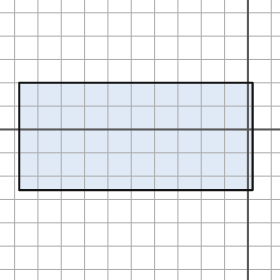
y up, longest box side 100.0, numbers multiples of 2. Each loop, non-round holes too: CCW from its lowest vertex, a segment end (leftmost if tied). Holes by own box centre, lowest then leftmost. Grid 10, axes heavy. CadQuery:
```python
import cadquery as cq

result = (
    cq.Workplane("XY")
    .moveTo(-98.0, -26.0)
    .lineTo(2.0, -26.0)
    .lineTo(2.0, 20.0)
    .lineTo(-98.0, 20.0)
    .close()
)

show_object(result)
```